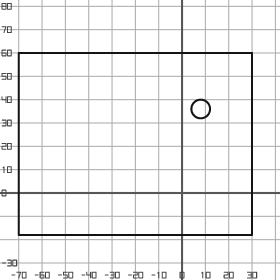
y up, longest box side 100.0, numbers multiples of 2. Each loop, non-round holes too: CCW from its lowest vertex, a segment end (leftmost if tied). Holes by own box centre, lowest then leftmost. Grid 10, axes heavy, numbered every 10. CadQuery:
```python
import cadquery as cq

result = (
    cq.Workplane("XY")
    .moveTo(-70.0, -18.0)
    .lineTo(30.0, -18.0)
    .lineTo(30.0, 60.0)
    .lineTo(-70.0, 60.0)
    .close()
    .moveTo(8.0, 36.0)
    .circle(4.0)
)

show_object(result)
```